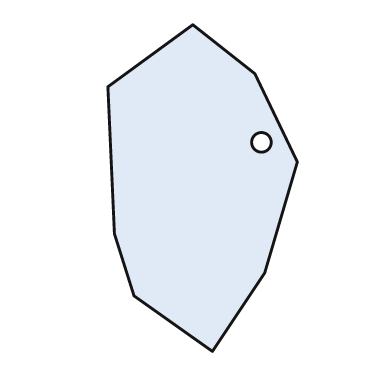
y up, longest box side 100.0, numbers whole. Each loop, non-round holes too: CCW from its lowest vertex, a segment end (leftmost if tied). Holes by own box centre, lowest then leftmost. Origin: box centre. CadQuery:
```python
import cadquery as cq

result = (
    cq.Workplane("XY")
    .moveTo(3.0, -50.0)
    .lineTo(19.0, -26.0)
    .lineTo(29.0, 8.0)
    .lineTo(16.0, 35.0)
    .lineTo(-3.0, 50.0)
    .lineTo(-29.0, 31.0)
    .lineTo(-27.0, -14.0)
    .lineTo(-21.0, -33.0)
    .close()
    .moveTo(18.0, 14.0)
    .circle(3.0)
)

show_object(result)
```